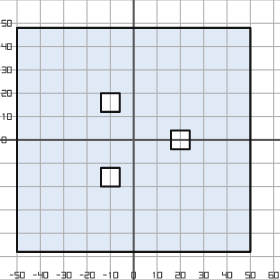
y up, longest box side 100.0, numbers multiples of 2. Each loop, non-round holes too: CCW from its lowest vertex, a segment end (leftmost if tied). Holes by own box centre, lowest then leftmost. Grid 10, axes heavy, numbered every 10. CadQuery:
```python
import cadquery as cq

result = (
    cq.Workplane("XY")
    .moveTo(-50.0, -48.0)
    .lineTo(50.0, -48.0)
    .lineTo(50.0, 48.0)
    .lineTo(-50.0, 48.0)
    .close()
    .moveTo(-14.0, -20.0)
    .lineTo(-6.0, -20.0)
    .lineTo(-6.0, -12.0)
    .lineTo(-14.0, -12.0)
    .close()
    .moveTo(16.0, -4.0)
    .lineTo(24.0, -4.0)
    .lineTo(24.0, 4.0)
    .lineTo(16.0, 4.0)
    .close()
    .moveTo(-14.0, 12.0)
    .lineTo(-6.0, 12.0)
    .lineTo(-6.0, 20.0)
    .lineTo(-14.0, 20.0)
    .close()
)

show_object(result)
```